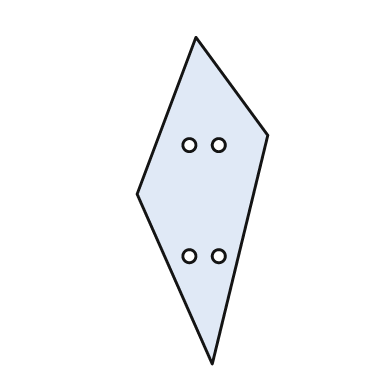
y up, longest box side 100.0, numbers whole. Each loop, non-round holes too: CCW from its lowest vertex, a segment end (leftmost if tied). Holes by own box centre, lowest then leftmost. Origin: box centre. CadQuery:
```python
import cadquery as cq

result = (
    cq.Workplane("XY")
    .moveTo(3.0, -50.0)
    .lineTo(20.0, 20.0)
    .lineTo(-2.0, 50.0)
    .lineTo(-20.0, 2.0)
    .close()
    .moveTo(-4.0, -17.0)
    .circle(2.0)
    .moveTo(5.0, -17.0)
    .circle(2.0)
    .moveTo(-4.0, 17.0)
    .circle(2.0)
    .moveTo(5.0, 17.0)
    .circle(2.0)
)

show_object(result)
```